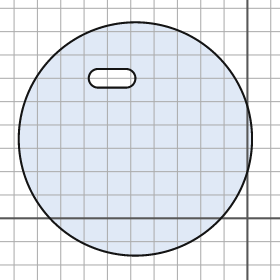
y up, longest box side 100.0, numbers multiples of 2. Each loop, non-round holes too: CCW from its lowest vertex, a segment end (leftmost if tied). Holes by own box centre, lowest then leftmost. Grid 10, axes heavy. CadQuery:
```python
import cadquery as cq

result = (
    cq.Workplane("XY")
    .moveTo(-48.0, 34.0)
    .circle(50.0)
    .moveTo(-64.0, 56.0)
    .lineTo(-52.0, 56.0)
    .threePointArc((-48.0, 60.0), (-52.0, 64.0))
    .lineTo(-64.0, 64.0)
    .threePointArc((-68.0, 60.0), (-64.0, 56.0))
    .close()
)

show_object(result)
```